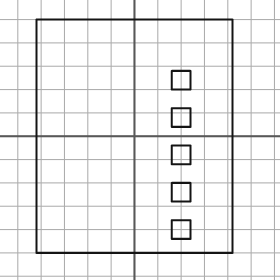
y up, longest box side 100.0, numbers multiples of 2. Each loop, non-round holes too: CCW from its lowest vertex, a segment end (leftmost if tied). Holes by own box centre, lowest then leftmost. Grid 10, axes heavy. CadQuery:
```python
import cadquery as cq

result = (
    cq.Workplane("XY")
    .moveTo(-42.0, -50.0)
    .lineTo(42.0, -50.0)
    .lineTo(42.0, 50.0)
    .lineTo(-42.0, 50.0)
    .close()
    .moveTo(16.0, -44.0)
    .lineTo(24.0, -44.0)
    .lineTo(24.0, -36.0)
    .lineTo(16.0, -36.0)
    .close()
    .moveTo(16.0, -28.0)
    .lineTo(24.0, -28.0)
    .lineTo(24.0, -20.0)
    .lineTo(16.0, -20.0)
    .close()
    .moveTo(16.0, -12.0)
    .lineTo(24.0, -12.0)
    .lineTo(24.0, -4.0)
    .lineTo(16.0, -4.0)
    .close()
    .moveTo(16.0, 4.0)
    .lineTo(24.0, 4.0)
    .lineTo(24.0, 12.0)
    .lineTo(16.0, 12.0)
    .close()
    .moveTo(16.0, 20.0)
    .lineTo(24.0, 20.0)
    .lineTo(24.0, 28.0)
    .lineTo(16.0, 28.0)
    .close()
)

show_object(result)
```